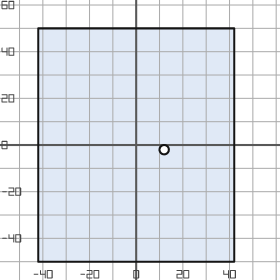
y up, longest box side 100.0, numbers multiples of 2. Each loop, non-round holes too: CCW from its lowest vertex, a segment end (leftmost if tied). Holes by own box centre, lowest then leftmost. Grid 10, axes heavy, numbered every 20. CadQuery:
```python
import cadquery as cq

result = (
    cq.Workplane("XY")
    .moveTo(-42.0, -50.0)
    .lineTo(42.0, -50.0)
    .lineTo(42.0, 50.0)
    .lineTo(-42.0, 50.0)
    .close()
    .moveTo(12.0, -2.0)
    .circle(2.0)
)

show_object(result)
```